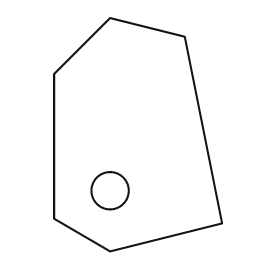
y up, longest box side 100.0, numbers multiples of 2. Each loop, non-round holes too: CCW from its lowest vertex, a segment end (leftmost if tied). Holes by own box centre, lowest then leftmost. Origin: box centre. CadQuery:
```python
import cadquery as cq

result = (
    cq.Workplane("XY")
    .moveTo(-12.0, -50.0)
    .lineTo(36.0, -38.0)
    .lineTo(20.0, 42.0)
    .lineTo(-12.0, 50.0)
    .lineTo(-36.0, 26.0)
    .lineTo(-36.0, -36.0)
    .close()
    .moveTo(-12.0, -24.0)
    .circle(8.0)
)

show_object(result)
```